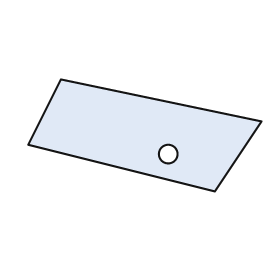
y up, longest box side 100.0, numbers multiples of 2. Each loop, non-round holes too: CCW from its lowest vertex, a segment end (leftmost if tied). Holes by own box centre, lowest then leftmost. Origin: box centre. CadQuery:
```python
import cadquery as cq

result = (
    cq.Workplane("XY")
    .moveTo(30.0, -24.0)
    .lineTo(50.0, 6.0)
    .lineTo(-36.0, 24.0)
    .lineTo(-50.0, -4.0)
    .close()
    .moveTo(10.0, -8.0)
    .circle(4.0)
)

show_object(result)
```